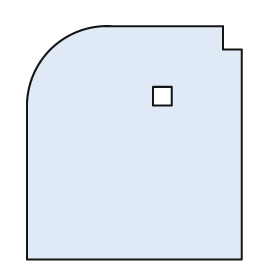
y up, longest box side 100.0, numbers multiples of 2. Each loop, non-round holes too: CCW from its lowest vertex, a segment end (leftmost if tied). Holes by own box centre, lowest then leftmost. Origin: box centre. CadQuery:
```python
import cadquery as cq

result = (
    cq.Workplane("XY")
    .moveTo(-46.0, -50.0)
    .lineTo(46.0, -50.0)
    .lineTo(46.0, 40.0)
    .lineTo(38.0, 40.0)
    .lineTo(38.0, 50.0)
    .lineTo(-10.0, 50.0)
    .threePointArc((-36.0, 40.0), (-46.0, 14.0))
    .close()
    .moveTo(8.0, 16.0)
    .lineTo(16.0, 16.0)
    .lineTo(16.0, 24.0)
    .lineTo(8.0, 24.0)
    .close()
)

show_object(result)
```